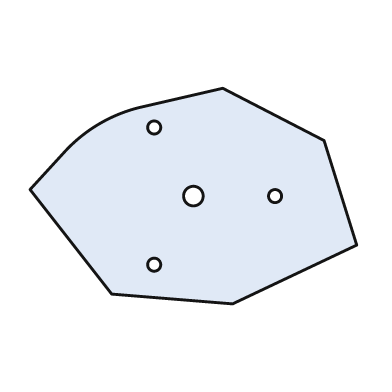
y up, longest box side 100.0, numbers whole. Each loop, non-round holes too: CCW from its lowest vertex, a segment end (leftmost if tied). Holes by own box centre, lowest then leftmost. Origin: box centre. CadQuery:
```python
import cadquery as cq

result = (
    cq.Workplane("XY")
    .moveTo(12.0, -33.0)
    .lineTo(50.0, -15.0)
    .lineTo(40.0, 17.0)
    .lineTo(9.0, 33.0)
    .lineTo(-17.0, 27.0)
    .threePointArc((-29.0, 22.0), (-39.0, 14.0))
    .lineTo(-50.0, 2.0)
    .lineTo(-25.0, -30.0)
    .close()
    .moveTo(-12.0, -21.0)
    .circle(2.0)
    .moveTo(0.0, 0.0)
    .circle(3.0)
    .moveTo(25.0, 0.0)
    .circle(2.0)
    .moveTo(-12.0, 21.0)
    .circle(2.0)
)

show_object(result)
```